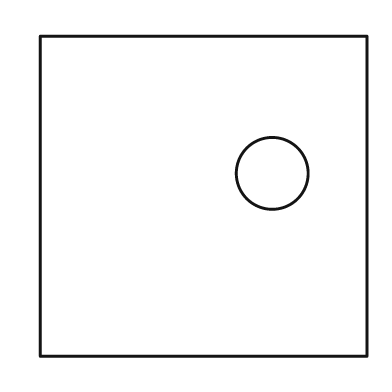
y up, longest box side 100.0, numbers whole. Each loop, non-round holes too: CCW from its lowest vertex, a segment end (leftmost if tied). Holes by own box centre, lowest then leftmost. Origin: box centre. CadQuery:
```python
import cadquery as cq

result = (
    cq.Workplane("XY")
    .moveTo(-50.0, -49.0)
    .lineTo(50.0, -49.0)
    .lineTo(50.0, 49.0)
    .lineTo(-50.0, 49.0)
    .close()
    .moveTo(21.0, 7.0)
    .circle(11.0)
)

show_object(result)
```